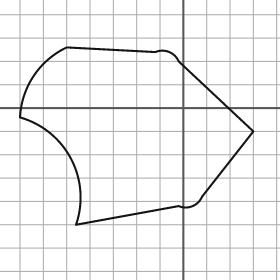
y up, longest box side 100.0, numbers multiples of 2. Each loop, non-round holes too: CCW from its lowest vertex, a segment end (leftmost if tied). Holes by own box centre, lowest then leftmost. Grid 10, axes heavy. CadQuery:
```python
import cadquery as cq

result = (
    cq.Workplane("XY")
    .moveTo(-46.0, -50.0)
    .lineTo(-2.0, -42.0)
    .threePointArc((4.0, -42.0), (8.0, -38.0))
    .lineTo(30.0, -10.0)
    .lineTo(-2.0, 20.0)
    .threePointArc((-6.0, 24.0), (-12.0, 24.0))
    .lineTo(-50.0, 26.0)
    .threePointArc((-64.0, 14.0), (-70.0, -4.0))
    .threePointArc((-48.0, -22.0), (-46.0, -50.0))
    .close()
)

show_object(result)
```